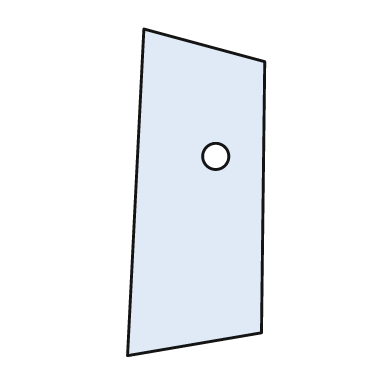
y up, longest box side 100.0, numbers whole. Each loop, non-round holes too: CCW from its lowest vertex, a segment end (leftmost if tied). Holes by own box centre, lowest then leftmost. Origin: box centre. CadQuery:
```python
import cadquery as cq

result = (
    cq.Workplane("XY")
    .moveTo(-21.0, -50.0)
    .lineTo(20.0, -43.0)
    .lineTo(21.0, 40.0)
    .lineTo(-16.0, 50.0)
    .close()
    .moveTo(6.0, 11.0)
    .circle(4.0)
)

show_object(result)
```